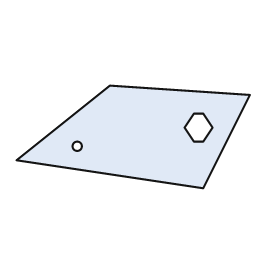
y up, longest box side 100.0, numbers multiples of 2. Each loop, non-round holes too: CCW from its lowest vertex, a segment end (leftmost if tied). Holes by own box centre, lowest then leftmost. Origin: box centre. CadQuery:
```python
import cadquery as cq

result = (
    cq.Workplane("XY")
    .moveTo(30.0, -22.0)
    .lineTo(50.0, 18.0)
    .lineTo(-10.0, 22.0)
    .lineTo(-50.0, -10.0)
    .close()
    .moveTo(-24.0, -4.0)
    .circle(2.0)
    .moveTo(26.0, -2.0)
    .lineTo(30.0, -2.0)
    .lineTo(34.0, 4.0)
    .lineTo(30.0, 10.0)
    .lineTo(26.0, 10.0)
    .lineTo(22.0, 4.0)
    .close()
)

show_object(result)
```